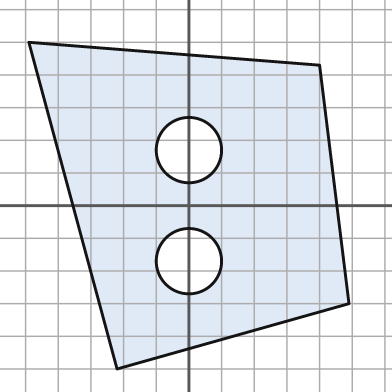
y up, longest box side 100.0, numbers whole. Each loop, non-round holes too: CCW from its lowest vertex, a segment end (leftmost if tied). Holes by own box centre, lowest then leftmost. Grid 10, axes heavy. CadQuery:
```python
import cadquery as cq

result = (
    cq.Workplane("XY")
    .moveTo(-22.0, -50.0)
    .lineTo(49.0, -30.0)
    .lineTo(40.0, 43.0)
    .lineTo(-49.0, 50.0)
    .close()
    .moveTo(0.0, -17.0)
    .circle(10.0)
    .moveTo(0.0, 17.0)
    .circle(10.0)
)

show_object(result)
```